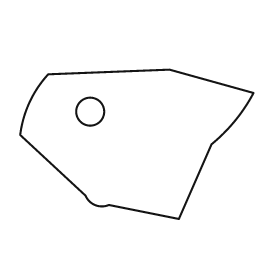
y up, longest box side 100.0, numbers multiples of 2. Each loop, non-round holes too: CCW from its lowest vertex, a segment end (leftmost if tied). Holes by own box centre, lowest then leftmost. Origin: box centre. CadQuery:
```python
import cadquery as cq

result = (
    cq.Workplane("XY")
    .moveTo(18.0, -32.0)
    .lineTo(32.0, 0.0)
    .threePointArc((42.0, 10.0), (50.0, 22.0))
    .lineTo(14.0, 32.0)
    .lineTo(-38.0, 30.0)
    .threePointArc((-46.0, 18.0), (-50.0, 4.0))
    .lineTo(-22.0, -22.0)
    .threePointArc((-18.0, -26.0), (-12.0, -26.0))
    .close()
    .moveTo(-20.0, 14.0)
    .circle(6.0)
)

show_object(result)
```